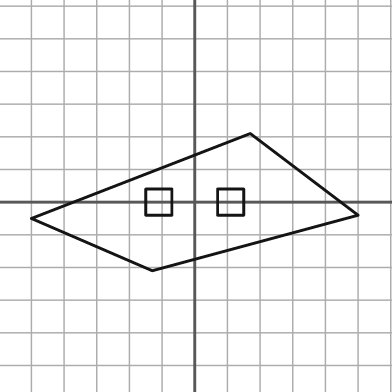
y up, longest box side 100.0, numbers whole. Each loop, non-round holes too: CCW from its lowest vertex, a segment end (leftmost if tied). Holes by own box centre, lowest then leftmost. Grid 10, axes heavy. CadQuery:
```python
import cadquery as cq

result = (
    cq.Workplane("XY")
    .moveTo(-13.0, -21.0)
    .lineTo(50.0, -4.0)
    .lineTo(17.0, 21.0)
    .lineTo(-50.0, -5.0)
    .close()
    .moveTo(-15.0, -4.0)
    .lineTo(-7.0, -4.0)
    .lineTo(-7.0, 4.0)
    .lineTo(-15.0, 4.0)
    .close()
    .moveTo(7.0, -4.0)
    .lineTo(15.0, -4.0)
    .lineTo(15.0, 4.0)
    .lineTo(7.0, 4.0)
    .close()
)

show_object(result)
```